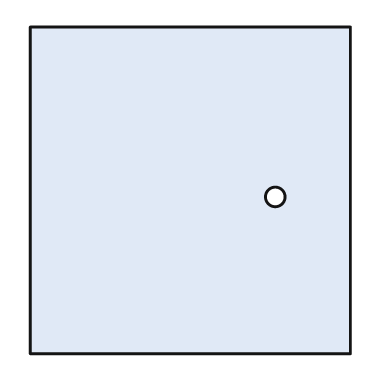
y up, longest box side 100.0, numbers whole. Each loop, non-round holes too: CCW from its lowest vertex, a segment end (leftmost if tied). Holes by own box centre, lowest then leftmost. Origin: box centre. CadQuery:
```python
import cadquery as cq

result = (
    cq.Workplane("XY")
    .moveTo(-49.0, -50.0)
    .lineTo(49.0, -50.0)
    .lineTo(49.0, 50.0)
    .lineTo(-49.0, 50.0)
    .close()
    .moveTo(26.0, -2.0)
    .circle(3.0)
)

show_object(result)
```